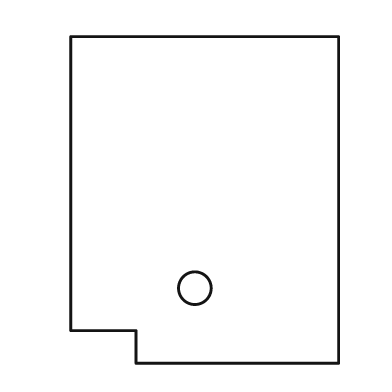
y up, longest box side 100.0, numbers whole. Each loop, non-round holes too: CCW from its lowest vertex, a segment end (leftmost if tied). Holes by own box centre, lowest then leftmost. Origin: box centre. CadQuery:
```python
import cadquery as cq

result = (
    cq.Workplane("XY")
    .moveTo(-21.0, -50.0)
    .lineTo(41.0, -50.0)
    .lineTo(41.0, 50.0)
    .lineTo(-41.0, 50.0)
    .lineTo(-41.0, -40.0)
    .lineTo(-21.0, -40.0)
    .close()
    .moveTo(-3.0, -27.0)
    .circle(5.0)
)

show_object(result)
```